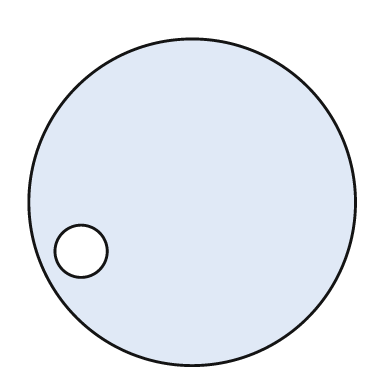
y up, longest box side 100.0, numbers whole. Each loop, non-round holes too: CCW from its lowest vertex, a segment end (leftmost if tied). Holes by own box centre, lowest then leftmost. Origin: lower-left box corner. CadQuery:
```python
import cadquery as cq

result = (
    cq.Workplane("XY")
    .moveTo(50.0, 50.0)
    .circle(50.0)
    .moveTo(16.0, 35.0)
    .circle(8.0)
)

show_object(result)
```